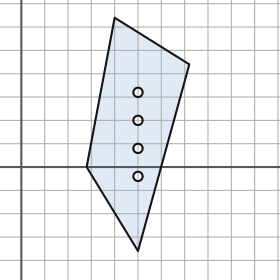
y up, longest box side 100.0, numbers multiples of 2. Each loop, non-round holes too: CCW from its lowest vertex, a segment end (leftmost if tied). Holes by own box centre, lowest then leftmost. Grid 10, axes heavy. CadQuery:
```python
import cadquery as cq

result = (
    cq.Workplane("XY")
    .moveTo(50.0, -36.0)
    .lineTo(72.0, 44.0)
    .lineTo(40.0, 64.0)
    .lineTo(28.0, 0.0)
    .close()
    .moveTo(50.0, -4.0)
    .circle(2.0)
    .moveTo(50.0, 8.0)
    .circle(2.0)
    .moveTo(50.0, 20.0)
    .circle(2.0)
    .moveTo(50.0, 32.0)
    .circle(2.0)
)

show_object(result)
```